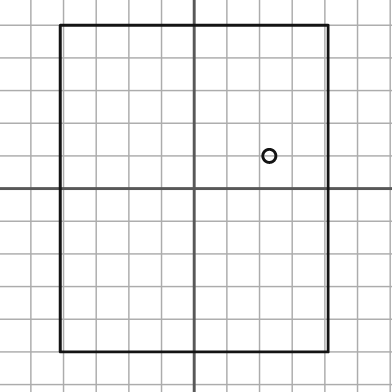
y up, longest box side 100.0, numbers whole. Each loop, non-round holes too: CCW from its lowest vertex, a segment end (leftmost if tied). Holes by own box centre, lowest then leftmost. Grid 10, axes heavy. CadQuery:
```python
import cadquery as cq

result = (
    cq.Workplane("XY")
    .moveTo(-41.0, -50.0)
    .lineTo(41.0, -50.0)
    .lineTo(41.0, 50.0)
    .lineTo(-41.0, 50.0)
    .close()
    .moveTo(23.0, 10.0)
    .circle(2.0)
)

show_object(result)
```